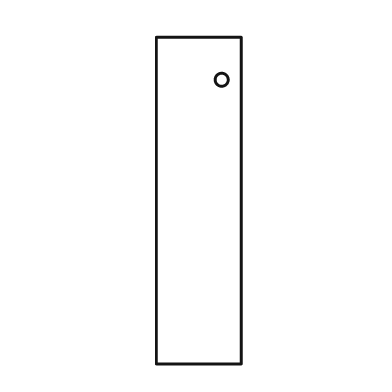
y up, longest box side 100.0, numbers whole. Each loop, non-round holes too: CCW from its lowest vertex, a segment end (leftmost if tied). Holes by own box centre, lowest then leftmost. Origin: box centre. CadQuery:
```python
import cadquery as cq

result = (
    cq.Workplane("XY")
    .moveTo(-13.0, -50.0)
    .lineTo(13.0, -50.0)
    .lineTo(13.0, 50.0)
    .lineTo(-13.0, 50.0)
    .close()
    .moveTo(7.0, 37.0)
    .circle(2.0)
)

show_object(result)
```